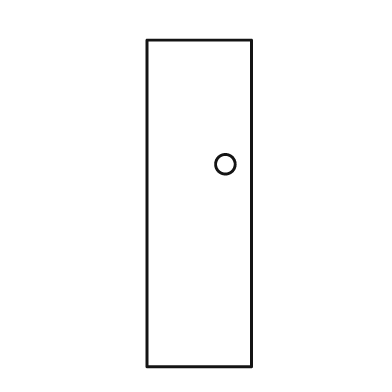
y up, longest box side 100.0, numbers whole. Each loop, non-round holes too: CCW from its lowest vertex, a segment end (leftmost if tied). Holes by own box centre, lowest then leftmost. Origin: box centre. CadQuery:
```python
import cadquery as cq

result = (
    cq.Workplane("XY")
    .moveTo(-16.0, -50.0)
    .lineTo(16.0, -50.0)
    .lineTo(16.0, 50.0)
    .lineTo(-16.0, 50.0)
    .close()
    .moveTo(8.0, 12.0)
    .circle(3.0)
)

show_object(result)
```